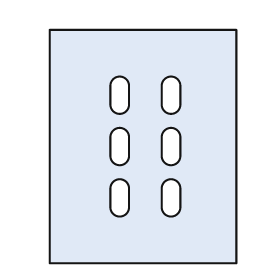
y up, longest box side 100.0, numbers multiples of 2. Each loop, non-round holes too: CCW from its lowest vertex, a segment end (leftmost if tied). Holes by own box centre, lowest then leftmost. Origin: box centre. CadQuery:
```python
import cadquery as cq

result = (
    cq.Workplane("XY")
    .moveTo(-40.0, -50.0)
    .lineTo(40.0, -50.0)
    .lineTo(40.0, 50.0)
    .lineTo(-40.0, 50.0)
    .close()
    .moveTo(-14.0, -26.0)
    .threePointArc((-10.0, -30.0), (-6.0, -26.0))
    .lineTo(-6.0, -18.0)
    .threePointArc((-10.0, -14.0), (-14.0, -18.0))
    .close()
    .moveTo(8.0, -26.0)
    .threePointArc((12.0, -30.0), (16.0, -26.0))
    .lineTo(16.0, -18.0)
    .threePointArc((12.0, -14.0), (8.0, -18.0))
    .close()
    .moveTo(-14.0, -4.0)
    .threePointArc((-10.0, -8.0), (-6.0, -4.0))
    .lineTo(-6.0, 4.0)
    .threePointArc((-10.0, 8.0), (-14.0, 4.0))
    .close()
    .moveTo(8.0, -4.0)
    .threePointArc((12.0, -8.0), (16.0, -4.0))
    .lineTo(16.0, 4.0)
    .threePointArc((12.0, 8.0), (8.0, 4.0))
    .close()
    .moveTo(-14.0, 18.0)
    .threePointArc((-10.0, 14.0), (-6.0, 18.0))
    .lineTo(-6.0, 26.0)
    .threePointArc((-10.0, 30.0), (-14.0, 26.0))
    .close()
    .moveTo(8.0, 18.0)
    .threePointArc((12.0, 14.0), (16.0, 18.0))
    .lineTo(16.0, 26.0)
    .threePointArc((12.0, 30.0), (8.0, 26.0))
    .close()
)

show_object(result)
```